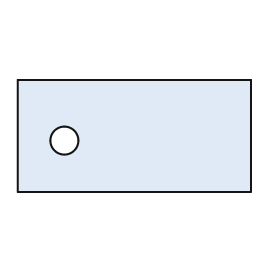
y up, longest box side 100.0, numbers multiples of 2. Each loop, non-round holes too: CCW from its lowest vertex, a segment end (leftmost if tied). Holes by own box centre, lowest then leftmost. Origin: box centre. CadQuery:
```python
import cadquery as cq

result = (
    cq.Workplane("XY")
    .moveTo(-50.0, -24.0)
    .lineTo(50.0, -24.0)
    .lineTo(50.0, 24.0)
    .lineTo(-50.0, 24.0)
    .close()
    .moveTo(-30.0, -2.0)
    .circle(6.0)
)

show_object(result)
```